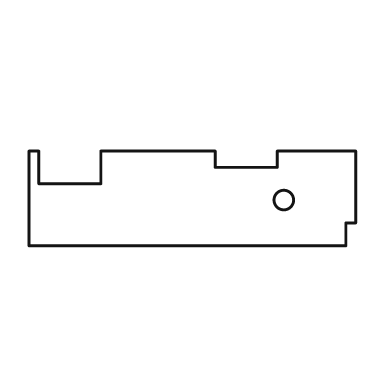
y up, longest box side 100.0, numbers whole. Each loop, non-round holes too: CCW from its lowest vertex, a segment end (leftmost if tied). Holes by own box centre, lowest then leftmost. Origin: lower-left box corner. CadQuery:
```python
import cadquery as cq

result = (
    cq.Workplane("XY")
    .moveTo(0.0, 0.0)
    .lineTo(97.0, 0.0)
    .lineTo(97.0, 7.0)
    .lineTo(100.0, 7.0)
    .lineTo(100.0, 29.0)
    .lineTo(76.0, 29.0)
    .lineTo(76.0, 24.0)
    .lineTo(57.0, 24.0)
    .lineTo(57.0, 29.0)
    .lineTo(22.0, 29.0)
    .lineTo(22.0, 19.0)
    .lineTo(3.0, 19.0)
    .lineTo(3.0, 29.0)
    .lineTo(0.0, 29.0)
    .close()
    .moveTo(78.0, 14.0)
    .circle(3.0)
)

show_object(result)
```